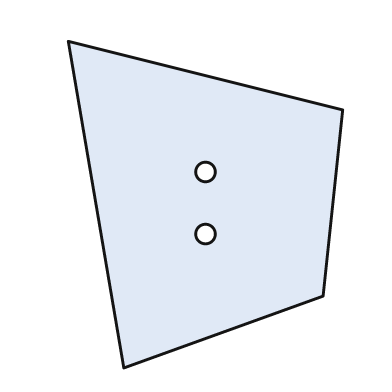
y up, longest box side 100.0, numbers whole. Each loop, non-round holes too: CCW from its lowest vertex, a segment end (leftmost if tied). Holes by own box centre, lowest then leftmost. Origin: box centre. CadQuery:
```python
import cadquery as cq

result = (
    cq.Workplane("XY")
    .moveTo(-25.0, -50.0)
    .lineTo(36.0, -28.0)
    .lineTo(42.0, 29.0)
    .lineTo(-42.0, 50.0)
    .close()
    .moveTo(0.0, -9.0)
    .circle(3.0)
    .moveTo(0.0, 10.0)
    .circle(3.0)
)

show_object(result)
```